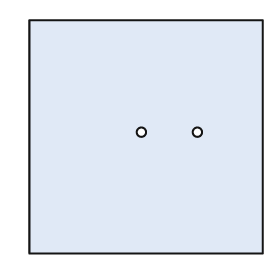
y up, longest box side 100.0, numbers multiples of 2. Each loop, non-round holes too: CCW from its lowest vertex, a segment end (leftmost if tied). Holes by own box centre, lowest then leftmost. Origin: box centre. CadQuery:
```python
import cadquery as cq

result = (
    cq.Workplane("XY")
    .moveTo(-50.0, -50.0)
    .lineTo(50.0, -50.0)
    .lineTo(50.0, 50.0)
    .lineTo(-50.0, 50.0)
    .close()
    .moveTo(-2.0, 2.0)
    .circle(2.0)
    .moveTo(22.0, 2.0)
    .circle(2.0)
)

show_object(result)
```